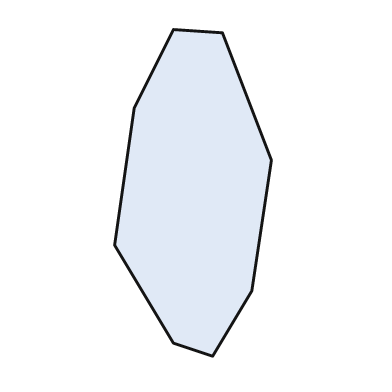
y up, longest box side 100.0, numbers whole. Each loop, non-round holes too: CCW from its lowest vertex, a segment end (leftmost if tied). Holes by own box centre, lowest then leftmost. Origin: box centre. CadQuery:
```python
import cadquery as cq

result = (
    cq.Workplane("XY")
    .moveTo(6.0, -50.0)
    .lineTo(18.0, -30.0)
    .lineTo(24.0, 10.0)
    .lineTo(9.0, 49.0)
    .lineTo(-6.0, 50.0)
    .lineTo(-18.0, 26.0)
    .lineTo(-24.0, -16.0)
    .lineTo(-6.0, -46.0)
    .close()
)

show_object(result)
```